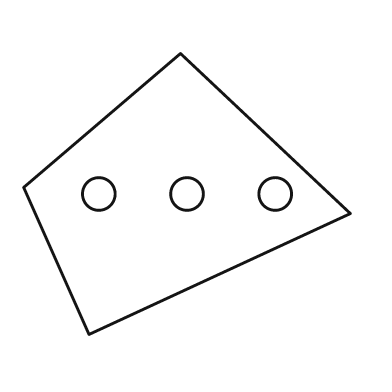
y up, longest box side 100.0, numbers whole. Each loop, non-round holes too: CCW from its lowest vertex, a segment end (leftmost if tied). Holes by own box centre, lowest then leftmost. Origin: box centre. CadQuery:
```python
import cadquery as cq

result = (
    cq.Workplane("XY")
    .moveTo(-30.0, -43.0)
    .lineTo(50.0, -6.0)
    .lineTo(-2.0, 43.0)
    .lineTo(-50.0, 2.0)
    .close()
    .moveTo(-27.0, 0.0)
    .circle(5.0)
    .moveTo(0.0, 0.0)
    .circle(5.0)
    .moveTo(27.0, 0.0)
    .circle(5.0)
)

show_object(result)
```